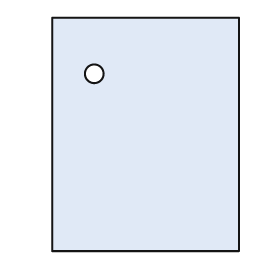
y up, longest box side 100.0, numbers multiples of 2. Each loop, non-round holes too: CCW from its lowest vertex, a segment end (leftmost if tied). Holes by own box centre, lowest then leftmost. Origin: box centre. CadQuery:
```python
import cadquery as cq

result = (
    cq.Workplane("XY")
    .moveTo(-40.0, -50.0)
    .lineTo(40.0, -50.0)
    .lineTo(40.0, 50.0)
    .lineTo(-40.0, 50.0)
    .close()
    .moveTo(-22.0, 26.0)
    .circle(4.0)
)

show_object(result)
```